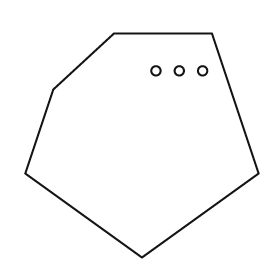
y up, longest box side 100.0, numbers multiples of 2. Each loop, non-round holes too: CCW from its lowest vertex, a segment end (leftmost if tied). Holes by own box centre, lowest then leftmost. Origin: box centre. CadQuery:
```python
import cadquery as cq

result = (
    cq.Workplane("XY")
    .moveTo(0.0, -48.0)
    .lineTo(50.0, -12.0)
    .lineTo(30.0, 48.0)
    .lineTo(-12.0, 48.0)
    .lineTo(-38.0, 24.0)
    .lineTo(-50.0, -12.0)
    .close()
    .moveTo(6.0, 32.0)
    .circle(2.0)
    .moveTo(16.0, 32.0)
    .circle(2.0)
    .moveTo(26.0, 32.0)
    .circle(2.0)
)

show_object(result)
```